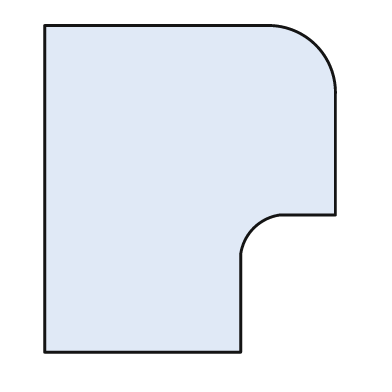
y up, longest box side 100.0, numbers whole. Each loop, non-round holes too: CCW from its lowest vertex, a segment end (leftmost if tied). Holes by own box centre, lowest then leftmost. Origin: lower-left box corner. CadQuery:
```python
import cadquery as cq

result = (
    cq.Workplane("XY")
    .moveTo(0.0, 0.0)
    .lineTo(60.0, 0.0)
    .lineTo(60.0, 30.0)
    .threePointArc((64.0, 38.0), (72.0, 42.0))
    .lineTo(89.0, 42.0)
    .lineTo(89.0, 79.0)
    .threePointArc((83.0, 94.0), (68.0, 100.0))
    .lineTo(0.0, 100.0)
    .close()
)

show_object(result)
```